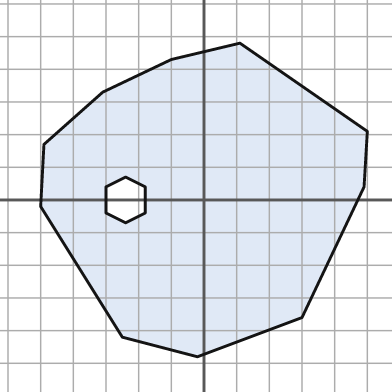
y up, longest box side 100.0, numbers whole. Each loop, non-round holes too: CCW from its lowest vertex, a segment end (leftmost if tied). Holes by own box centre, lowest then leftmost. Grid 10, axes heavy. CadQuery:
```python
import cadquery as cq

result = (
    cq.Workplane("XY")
    .moveTo(-2.0, -48.0)
    .lineTo(30.0, -36.0)
    .lineTo(49.0, 4.0)
    .lineTo(50.0, 21.0)
    .lineTo(11.0, 48.0)
    .lineTo(-10.0, 43.0)
    .lineTo(-31.0, 33.0)
    .lineTo(-49.0, 17.0)
    .lineTo(-50.0, -2.0)
    .lineTo(-25.0, -42.0)
    .close()
    .moveTo(-24.0, -7.0)
    .lineTo(-18.0, -4.0)
    .lineTo(-18.0, 4.0)
    .lineTo(-24.0, 7.0)
    .lineTo(-30.0, 4.0)
    .lineTo(-30.0, -4.0)
    .close()
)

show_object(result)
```